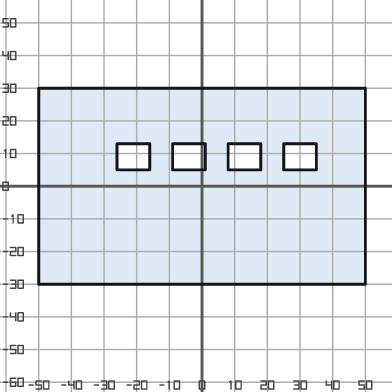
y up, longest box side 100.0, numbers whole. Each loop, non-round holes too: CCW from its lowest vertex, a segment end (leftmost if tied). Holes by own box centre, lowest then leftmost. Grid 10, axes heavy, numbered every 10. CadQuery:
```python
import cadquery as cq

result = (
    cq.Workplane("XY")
    .moveTo(-50.0, -30.0)
    .lineTo(50.0, -30.0)
    .lineTo(50.0, 30.0)
    .lineTo(-50.0, 30.0)
    .close()
    .moveTo(-26.0, 5.0)
    .lineTo(-16.0, 5.0)
    .lineTo(-16.0, 13.0)
    .lineTo(-26.0, 13.0)
    .close()
    .moveTo(-9.0, 5.0)
    .lineTo(1.0, 5.0)
    .lineTo(1.0, 13.0)
    .lineTo(-9.0, 13.0)
    .close()
    .moveTo(8.0, 5.0)
    .lineTo(18.0, 5.0)
    .lineTo(18.0, 13.0)
    .lineTo(8.0, 13.0)
    .close()
    .moveTo(25.0, 5.0)
    .lineTo(35.0, 5.0)
    .lineTo(35.0, 13.0)
    .lineTo(25.0, 13.0)
    .close()
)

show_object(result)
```